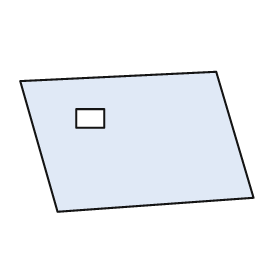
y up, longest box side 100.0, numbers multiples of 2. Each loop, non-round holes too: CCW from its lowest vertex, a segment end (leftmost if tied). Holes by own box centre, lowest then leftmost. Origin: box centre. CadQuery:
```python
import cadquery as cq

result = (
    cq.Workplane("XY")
    .moveTo(-34.0, -30.0)
    .lineTo(50.0, -24.0)
    .lineTo(34.0, 30.0)
    .lineTo(-50.0, 26.0)
    .close()
    .moveTo(-26.0, 6.0)
    .lineTo(-14.0, 6.0)
    .lineTo(-14.0, 14.0)
    .lineTo(-26.0, 14.0)
    .close()
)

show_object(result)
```